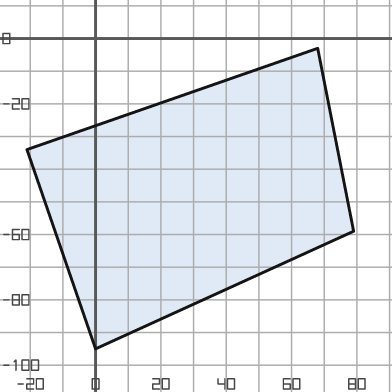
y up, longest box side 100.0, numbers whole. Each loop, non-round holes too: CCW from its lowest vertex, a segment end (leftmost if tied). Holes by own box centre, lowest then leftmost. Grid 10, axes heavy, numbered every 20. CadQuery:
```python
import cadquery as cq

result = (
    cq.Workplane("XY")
    .moveTo(0.0, -95.0)
    .lineTo(79.0, -59.0)
    .lineTo(68.0, -3.0)
    .lineTo(-21.0, -34.0)
    .close()
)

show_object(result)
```